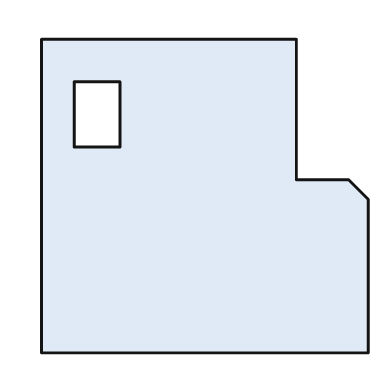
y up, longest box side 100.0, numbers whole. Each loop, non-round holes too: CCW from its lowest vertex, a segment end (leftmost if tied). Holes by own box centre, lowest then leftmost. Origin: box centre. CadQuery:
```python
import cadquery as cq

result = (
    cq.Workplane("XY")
    .moveTo(-50.0, -48.0)
    .lineTo(50.0, -48.0)
    .lineTo(50.0, -1.0)
    .lineTo(44.0, 5.0)
    .lineTo(28.0, 5.0)
    .lineTo(28.0, 48.0)
    .lineTo(-50.0, 48.0)
    .close()
    .moveTo(-40.0, 15.0)
    .lineTo(-26.0, 15.0)
    .lineTo(-26.0, 35.0)
    .lineTo(-40.0, 35.0)
    .close()
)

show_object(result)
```